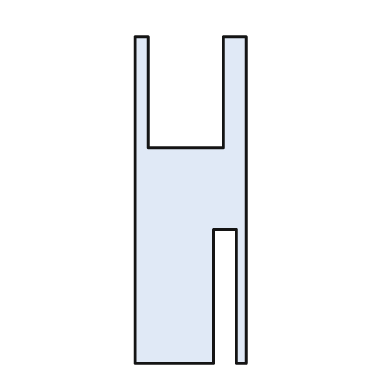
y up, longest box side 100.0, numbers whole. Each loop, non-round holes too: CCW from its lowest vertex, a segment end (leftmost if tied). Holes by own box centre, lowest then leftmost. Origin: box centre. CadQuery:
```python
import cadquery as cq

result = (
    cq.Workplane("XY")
    .moveTo(-17.0, -50.0)
    .lineTo(7.0, -50.0)
    .lineTo(7.0, -9.0)
    .lineTo(14.0, -9.0)
    .lineTo(14.0, -50.0)
    .lineTo(17.0, -50.0)
    .lineTo(17.0, 50.0)
    .lineTo(10.0, 50.0)
    .lineTo(10.0, 16.0)
    .lineTo(-13.0, 16.0)
    .lineTo(-13.0, 50.0)
    .lineTo(-17.0, 50.0)
    .close()
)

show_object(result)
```